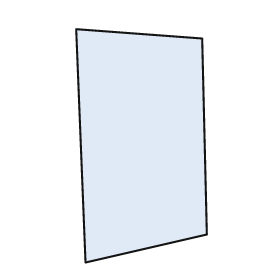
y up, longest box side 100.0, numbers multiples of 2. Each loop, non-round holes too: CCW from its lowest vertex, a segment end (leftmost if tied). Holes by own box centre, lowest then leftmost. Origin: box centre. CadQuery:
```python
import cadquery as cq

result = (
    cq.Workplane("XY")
    .moveTo(-24.0, -50.0)
    .lineTo(28.0, -38.0)
    .lineTo(26.0, 46.0)
    .lineTo(-28.0, 50.0)
    .close()
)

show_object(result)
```